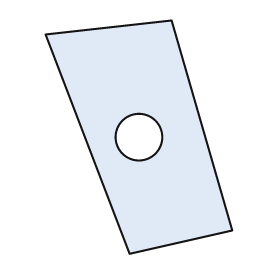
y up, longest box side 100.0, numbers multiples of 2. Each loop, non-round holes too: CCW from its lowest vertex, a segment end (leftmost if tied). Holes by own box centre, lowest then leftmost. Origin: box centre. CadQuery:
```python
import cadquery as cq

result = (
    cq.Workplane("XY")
    .moveTo(-4.0, -50.0)
    .lineTo(40.0, -40.0)
    .lineTo(14.0, 50.0)
    .lineTo(-40.0, 44.0)
    .close()
    .moveTo(0.0, 0.0)
    .circle(10.0)
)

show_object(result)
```